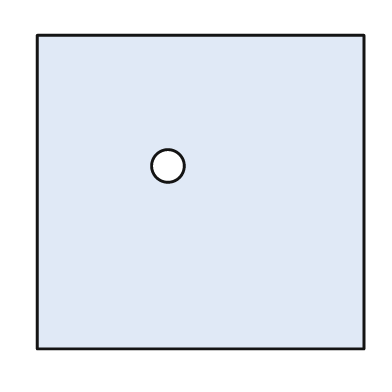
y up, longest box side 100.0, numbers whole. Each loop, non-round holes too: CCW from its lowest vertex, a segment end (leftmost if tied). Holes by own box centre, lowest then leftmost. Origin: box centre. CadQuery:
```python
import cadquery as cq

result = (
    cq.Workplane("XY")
    .moveTo(-50.0, -48.0)
    .lineTo(50.0, -48.0)
    .lineTo(50.0, 48.0)
    .lineTo(-50.0, 48.0)
    .close()
    .moveTo(-10.0, 8.0)
    .circle(5.0)
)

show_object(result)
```